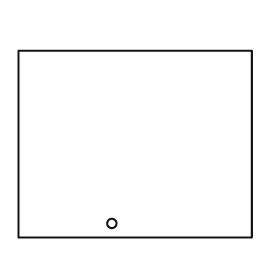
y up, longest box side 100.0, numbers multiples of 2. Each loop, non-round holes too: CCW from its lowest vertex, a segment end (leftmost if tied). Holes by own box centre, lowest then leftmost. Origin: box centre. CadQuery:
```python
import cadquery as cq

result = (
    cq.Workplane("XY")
    .moveTo(-50.0, -40.0)
    .lineTo(50.0, -40.0)
    .lineTo(50.0, 40.0)
    .lineTo(-50.0, 40.0)
    .close()
    .moveTo(-10.0, -34.0)
    .circle(2.0)
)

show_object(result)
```